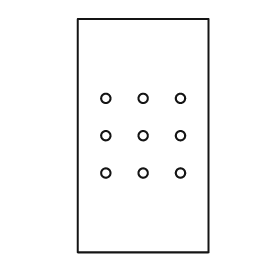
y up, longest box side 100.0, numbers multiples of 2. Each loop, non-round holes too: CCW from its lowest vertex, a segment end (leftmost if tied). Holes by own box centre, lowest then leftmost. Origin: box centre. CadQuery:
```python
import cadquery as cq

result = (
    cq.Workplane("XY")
    .moveTo(-28.0, -50.0)
    .lineTo(28.0, -50.0)
    .lineTo(28.0, 50.0)
    .lineTo(-28.0, 50.0)
    .close()
    .moveTo(-16.0, -16.0)
    .circle(2.0)
    .moveTo(0.0, -16.0)
    .circle(2.0)
    .moveTo(16.0, -16.0)
    .circle(2.0)
    .moveTo(-16.0, 0.0)
    .circle(2.0)
    .moveTo(0.0, 0.0)
    .circle(2.0)
    .moveTo(16.0, 0.0)
    .circle(2.0)
    .moveTo(-16.0, 16.0)
    .circle(2.0)
    .moveTo(0.0, 16.0)
    .circle(2.0)
    .moveTo(16.0, 16.0)
    .circle(2.0)
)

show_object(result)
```